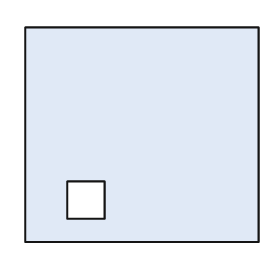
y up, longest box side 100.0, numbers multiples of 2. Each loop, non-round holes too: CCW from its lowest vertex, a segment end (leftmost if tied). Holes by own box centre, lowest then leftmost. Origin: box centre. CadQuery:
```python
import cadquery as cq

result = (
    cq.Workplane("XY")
    .moveTo(-50.0, -46.0)
    .lineTo(50.0, -46.0)
    .lineTo(50.0, 46.0)
    .lineTo(-50.0, 46.0)
    .close()
    .moveTo(-32.0, -36.0)
    .lineTo(-16.0, -36.0)
    .lineTo(-16.0, -20.0)
    .lineTo(-32.0, -20.0)
    .close()
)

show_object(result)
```